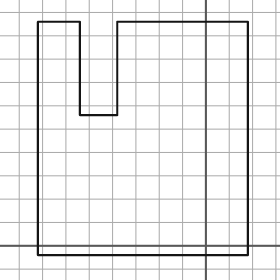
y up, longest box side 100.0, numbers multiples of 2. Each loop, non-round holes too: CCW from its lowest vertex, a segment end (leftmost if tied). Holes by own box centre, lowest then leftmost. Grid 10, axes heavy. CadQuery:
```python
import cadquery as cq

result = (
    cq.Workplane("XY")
    .moveTo(-72.0, -4.0)
    .lineTo(18.0, -4.0)
    .lineTo(18.0, 96.0)
    .lineTo(-38.0, 96.0)
    .lineTo(-38.0, 56.0)
    .lineTo(-54.0, 56.0)
    .lineTo(-54.0, 96.0)
    .lineTo(-72.0, 96.0)
    .close()
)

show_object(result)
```